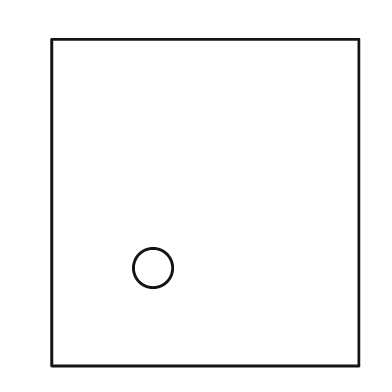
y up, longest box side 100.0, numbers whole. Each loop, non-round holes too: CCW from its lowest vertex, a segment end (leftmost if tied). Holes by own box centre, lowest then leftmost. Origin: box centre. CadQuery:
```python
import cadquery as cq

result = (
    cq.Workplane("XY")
    .moveTo(-47.0, -50.0)
    .lineTo(47.0, -50.0)
    .lineTo(47.0, 50.0)
    .lineTo(-47.0, 50.0)
    .close()
    .moveTo(-16.0, -20.0)
    .circle(6.0)
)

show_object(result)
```